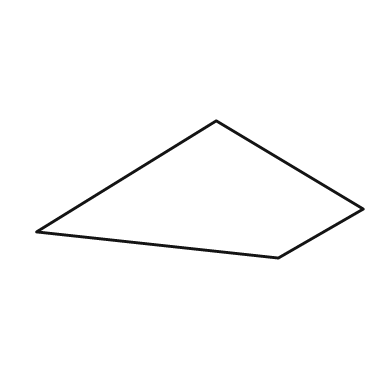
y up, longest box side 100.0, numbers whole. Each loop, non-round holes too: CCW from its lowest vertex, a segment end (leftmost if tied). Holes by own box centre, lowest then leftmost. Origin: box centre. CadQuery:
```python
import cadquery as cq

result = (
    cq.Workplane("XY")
    .moveTo(24.0, -21.0)
    .lineTo(50.0, -6.0)
    .lineTo(5.0, 21.0)
    .lineTo(-50.0, -13.0)
    .close()
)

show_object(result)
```